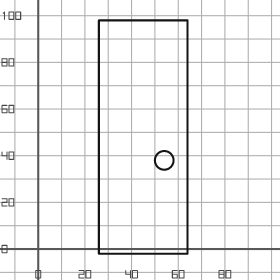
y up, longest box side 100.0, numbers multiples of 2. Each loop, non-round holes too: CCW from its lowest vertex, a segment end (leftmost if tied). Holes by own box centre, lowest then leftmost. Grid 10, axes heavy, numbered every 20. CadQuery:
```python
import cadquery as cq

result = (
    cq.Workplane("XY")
    .moveTo(26.0, -2.0)
    .lineTo(64.0, -2.0)
    .lineTo(64.0, 98.0)
    .lineTo(26.0, 98.0)
    .close()
    .moveTo(54.0, 38.0)
    .circle(4.0)
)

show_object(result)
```